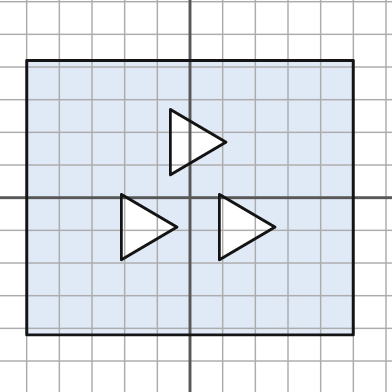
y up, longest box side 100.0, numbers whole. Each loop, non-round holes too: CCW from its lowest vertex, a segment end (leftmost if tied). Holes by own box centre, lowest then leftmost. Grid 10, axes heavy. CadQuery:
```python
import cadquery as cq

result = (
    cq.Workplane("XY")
    .moveTo(-50.0, -42.0)
    .lineTo(50.0, -42.0)
    .lineTo(50.0, 42.0)
    .lineTo(-50.0, 42.0)
    .close()
    .moveTo(-21.0, -19.0)
    .lineTo(-4.0, -9.0)
    .lineTo(-21.0, 1.0)
    .close()
    .moveTo(9.0, -19.0)
    .lineTo(26.0, -9.0)
    .lineTo(9.0, 1.0)
    .close()
    .moveTo(-6.0, 7.0)
    .lineTo(11.0, 17.0)
    .lineTo(-6.0, 27.0)
    .close()
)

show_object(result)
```